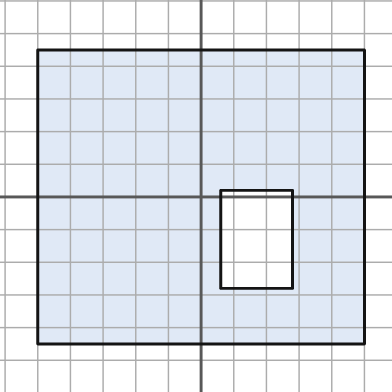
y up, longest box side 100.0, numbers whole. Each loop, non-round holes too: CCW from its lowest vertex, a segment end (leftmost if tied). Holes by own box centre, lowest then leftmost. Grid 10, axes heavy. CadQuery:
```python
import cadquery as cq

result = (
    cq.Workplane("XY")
    .moveTo(-50.0, -45.0)
    .lineTo(50.0, -45.0)
    .lineTo(50.0, 45.0)
    .lineTo(-50.0, 45.0)
    .close()
    .moveTo(6.0, -28.0)
    .lineTo(28.0, -28.0)
    .lineTo(28.0, 2.0)
    .lineTo(6.0, 2.0)
    .close()
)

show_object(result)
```